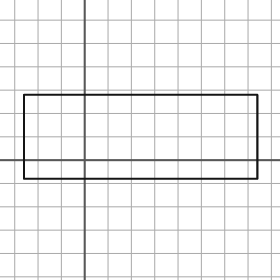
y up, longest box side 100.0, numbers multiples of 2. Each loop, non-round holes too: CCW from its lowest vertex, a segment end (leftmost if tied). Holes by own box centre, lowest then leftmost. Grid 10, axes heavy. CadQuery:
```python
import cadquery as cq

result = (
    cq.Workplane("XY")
    .moveTo(-26.0, -8.0)
    .lineTo(74.0, -8.0)
    .lineTo(74.0, 28.0)
    .lineTo(-26.0, 28.0)
    .close()
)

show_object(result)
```